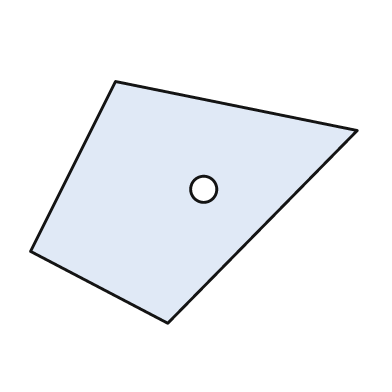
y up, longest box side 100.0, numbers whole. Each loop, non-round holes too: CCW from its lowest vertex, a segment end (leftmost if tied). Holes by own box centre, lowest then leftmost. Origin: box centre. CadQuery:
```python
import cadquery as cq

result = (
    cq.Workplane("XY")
    .moveTo(-8.0, -37.0)
    .lineTo(50.0, 22.0)
    .lineTo(-24.0, 37.0)
    .lineTo(-50.0, -15.0)
    .close()
    .moveTo(3.0, 4.0)
    .circle(4.0)
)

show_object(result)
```